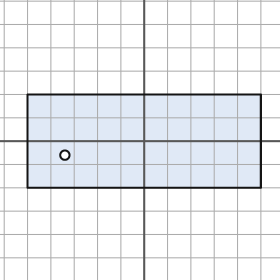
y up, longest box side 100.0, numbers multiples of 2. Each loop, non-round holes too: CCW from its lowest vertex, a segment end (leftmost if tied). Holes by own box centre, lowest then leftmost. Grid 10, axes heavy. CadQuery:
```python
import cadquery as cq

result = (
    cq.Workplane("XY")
    .moveTo(-50.0, -20.0)
    .lineTo(50.0, -20.0)
    .lineTo(50.0, 20.0)
    .lineTo(-50.0, 20.0)
    .close()
    .moveTo(-34.0, -6.0)
    .circle(2.0)
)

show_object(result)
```